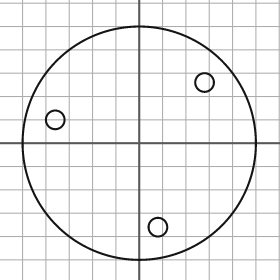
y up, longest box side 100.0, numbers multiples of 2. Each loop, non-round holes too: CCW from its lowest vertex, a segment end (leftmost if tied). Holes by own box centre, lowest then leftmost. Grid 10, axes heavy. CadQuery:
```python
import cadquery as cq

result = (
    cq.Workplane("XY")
    .moveTo(0.0, 0.0)
    .circle(50.0)
    .moveTo(8.0, -36.0)
    .circle(4.0)
    .moveTo(-36.0, 10.0)
    .circle(4.0)
    .moveTo(28.0, 26.0)
    .circle(4.0)
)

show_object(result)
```